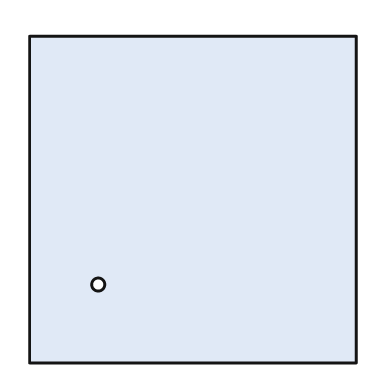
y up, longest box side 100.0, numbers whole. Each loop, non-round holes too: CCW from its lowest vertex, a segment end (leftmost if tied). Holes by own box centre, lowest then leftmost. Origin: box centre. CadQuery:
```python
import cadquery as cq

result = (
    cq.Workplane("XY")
    .moveTo(-50.0, -50.0)
    .lineTo(50.0, -50.0)
    .lineTo(50.0, 50.0)
    .lineTo(-50.0, 50.0)
    .close()
    .moveTo(-29.0, -26.0)
    .circle(2.0)
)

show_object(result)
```